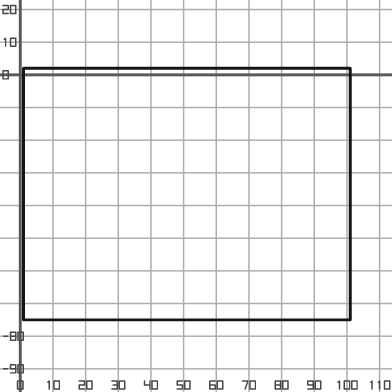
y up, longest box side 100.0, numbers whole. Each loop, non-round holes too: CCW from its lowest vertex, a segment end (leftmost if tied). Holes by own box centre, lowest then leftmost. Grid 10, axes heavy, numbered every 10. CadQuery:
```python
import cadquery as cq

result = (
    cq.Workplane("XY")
    .moveTo(1.0, -75.0)
    .lineTo(101.0, -75.0)
    .lineTo(101.0, 2.0)
    .lineTo(1.0, 2.0)
    .close()
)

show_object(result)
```